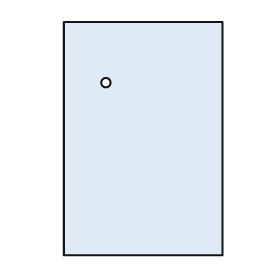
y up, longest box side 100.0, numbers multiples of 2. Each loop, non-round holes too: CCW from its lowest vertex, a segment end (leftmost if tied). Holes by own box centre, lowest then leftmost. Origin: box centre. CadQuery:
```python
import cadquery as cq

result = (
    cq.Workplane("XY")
    .moveTo(-34.0, -50.0)
    .lineTo(34.0, -50.0)
    .lineTo(34.0, 50.0)
    .lineTo(-34.0, 50.0)
    .close()
    .moveTo(-16.0, 24.0)
    .circle(2.0)
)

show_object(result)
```